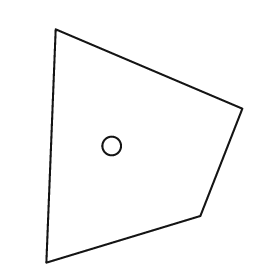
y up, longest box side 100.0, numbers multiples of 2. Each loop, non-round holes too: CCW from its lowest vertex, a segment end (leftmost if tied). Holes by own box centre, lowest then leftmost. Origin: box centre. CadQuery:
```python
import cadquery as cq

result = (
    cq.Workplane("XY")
    .moveTo(-42.0, -50.0)
    .lineTo(24.0, -30.0)
    .lineTo(42.0, 16.0)
    .lineTo(-38.0, 50.0)
    .close()
    .moveTo(-14.0, 0.0)
    .circle(4.0)
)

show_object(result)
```